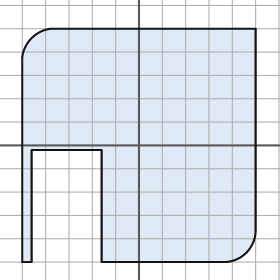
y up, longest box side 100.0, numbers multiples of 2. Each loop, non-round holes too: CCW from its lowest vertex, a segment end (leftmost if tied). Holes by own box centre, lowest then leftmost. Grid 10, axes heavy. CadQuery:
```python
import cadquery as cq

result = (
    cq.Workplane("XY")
    .moveTo(-50.0, -50.0)
    .lineTo(-46.0, -50.0)
    .lineTo(-46.0, -2.0)
    .lineTo(-16.0, -2.0)
    .lineTo(-16.0, -50.0)
    .lineTo(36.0, -50.0)
    .threePointArc((46.0, -46.0), (50.0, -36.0))
    .lineTo(50.0, 50.0)
    .lineTo(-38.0, 50.0)
    .threePointArc((-46.0, 46.0), (-50.0, 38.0))
    .close()
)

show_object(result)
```